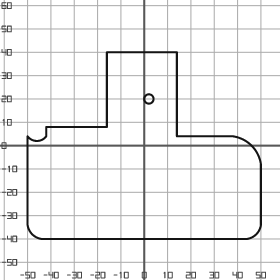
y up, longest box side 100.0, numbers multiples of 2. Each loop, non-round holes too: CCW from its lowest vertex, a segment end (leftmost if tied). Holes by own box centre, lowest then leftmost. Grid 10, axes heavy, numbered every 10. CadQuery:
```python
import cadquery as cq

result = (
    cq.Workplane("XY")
    .moveTo(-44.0, -40.0)
    .lineTo(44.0, -40.0)
    .threePointArc((48.0, -38.0), (50.0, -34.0))
    .lineTo(50.0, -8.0)
    .threePointArc((46.0, 0.0), (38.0, 4.0))
    .lineTo(14.0, 4.0)
    .lineTo(14.0, 40.0)
    .lineTo(-16.0, 40.0)
    .lineTo(-16.0, 8.0)
    .lineTo(-42.0, 8.0)
    .lineTo(-42.0, 4.0)
    .threePointArc((-46.0, 2.0), (-50.0, 4.0))
    .lineTo(-50.0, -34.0)
    .threePointArc((-48.0, -38.0), (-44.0, -40.0))
    .close()
    .moveTo(2.0, 20.0)
    .circle(2.0)
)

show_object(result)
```